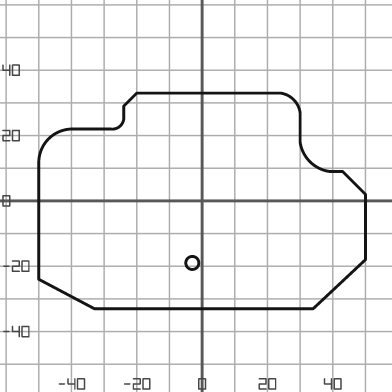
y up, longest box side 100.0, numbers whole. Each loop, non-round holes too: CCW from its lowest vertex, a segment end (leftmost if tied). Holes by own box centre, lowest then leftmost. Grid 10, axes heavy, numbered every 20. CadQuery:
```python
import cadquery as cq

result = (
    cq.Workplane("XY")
    .moveTo(-33.0, -33.0)
    .lineTo(34.0, -33.0)
    .lineTo(50.0, -18.0)
    .lineTo(50.0, 2.0)
    .lineTo(43.0, 9.0)
    .lineTo(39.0, 9.0)
    .threePointArc((33.0, 12.0), (30.0, 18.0))
    .lineTo(30.0, 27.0)
    .threePointArc((28.0, 31.0), (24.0, 33.0))
    .lineTo(-20.0, 33.0)
    .lineTo(-24.0, 29.0)
    .lineTo(-24.0, 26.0)
    .threePointArc((-25.0, 23.0), (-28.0, 22.0))
    .lineTo(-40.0, 22.0)
    .threePointArc((-47.0, 19.0), (-50.0, 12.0))
    .lineTo(-50.0, -24.0)
    .close()
    .moveTo(-3.0, -19.0)
    .circle(2.0)
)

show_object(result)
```